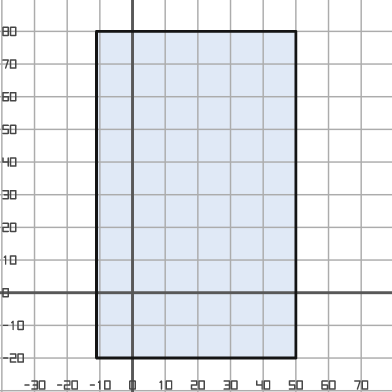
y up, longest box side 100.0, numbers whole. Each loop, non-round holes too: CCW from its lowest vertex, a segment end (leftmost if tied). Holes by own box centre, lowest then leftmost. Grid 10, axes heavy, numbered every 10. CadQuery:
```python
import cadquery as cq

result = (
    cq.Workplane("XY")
    .moveTo(-11.0, -20.0)
    .lineTo(50.0, -20.0)
    .lineTo(50.0, 80.0)
    .lineTo(-11.0, 80.0)
    .close()
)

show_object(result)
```